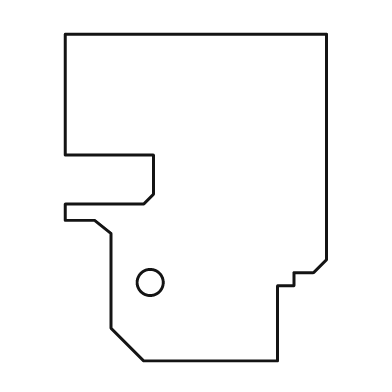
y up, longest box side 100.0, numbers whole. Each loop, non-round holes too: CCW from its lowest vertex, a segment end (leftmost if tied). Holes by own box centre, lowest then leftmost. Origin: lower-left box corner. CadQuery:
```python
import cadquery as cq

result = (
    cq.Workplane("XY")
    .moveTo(24.0, 0.0)
    .lineTo(65.0, 0.0)
    .lineTo(65.0, 23.0)
    .lineTo(70.0, 23.0)
    .lineTo(70.0, 27.0)
    .lineTo(76.0, 27.0)
    .lineTo(80.0, 31.0)
    .lineTo(80.0, 100.0)
    .lineTo(0.0, 100.0)
    .lineTo(0.0, 63.0)
    .lineTo(27.0, 63.0)
    .lineTo(27.0, 51.0)
    .lineTo(24.0, 48.0)
    .lineTo(0.0, 48.0)
    .lineTo(0.0, 43.0)
    .lineTo(9.0, 43.0)
    .lineTo(14.0, 39.0)
    .lineTo(14.0, 10.0)
    .close()
    .moveTo(26.0, 24.0)
    .circle(4.0)
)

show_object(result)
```